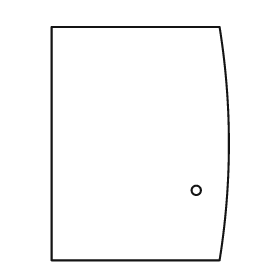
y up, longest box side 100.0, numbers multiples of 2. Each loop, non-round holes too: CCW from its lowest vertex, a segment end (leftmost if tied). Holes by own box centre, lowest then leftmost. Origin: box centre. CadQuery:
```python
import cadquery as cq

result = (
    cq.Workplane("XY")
    .moveTo(-38.0, -50.0)
    .lineTo(34.0, -50.0)
    .threePointArc((38.0, 0.0), (34.0, 50.0))
    .lineTo(-38.0, 50.0)
    .close()
    .moveTo(24.0, -20.0)
    .circle(2.0)
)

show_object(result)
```